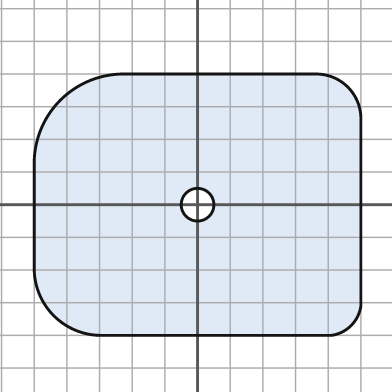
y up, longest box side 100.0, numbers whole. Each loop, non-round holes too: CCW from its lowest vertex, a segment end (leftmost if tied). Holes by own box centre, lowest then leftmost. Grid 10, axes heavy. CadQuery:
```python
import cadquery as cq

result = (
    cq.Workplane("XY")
    .moveTo(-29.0, -40.0)
    .lineTo(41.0, -40.0)
    .threePointArc((47.0, -37.0), (50.0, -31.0))
    .lineTo(50.0, 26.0)
    .threePointArc((46.0, 36.0), (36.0, 40.0))
    .lineTo(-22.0, 40.0)
    .threePointArc((-42.0, 32.0), (-50.0, 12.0))
    .lineTo(-50.0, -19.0)
    .threePointArc((-44.0, -34.0), (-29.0, -40.0))
    .close()
    .moveTo(0.0, 0.0)
    .circle(5.0)
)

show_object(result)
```